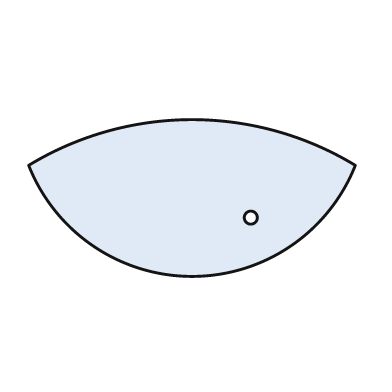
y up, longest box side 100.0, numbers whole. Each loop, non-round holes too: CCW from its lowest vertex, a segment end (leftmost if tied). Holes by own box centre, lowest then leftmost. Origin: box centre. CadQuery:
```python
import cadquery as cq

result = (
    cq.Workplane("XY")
    .moveTo(-50.0, 10.0)
    .threePointArc((0.0, -24.0), (50.0, 10.0))
    .threePointArc((0.0, 24.0), (-50.0, 10.0))
    .close()
    .moveTo(18.0, -6.0)
    .circle(2.0)
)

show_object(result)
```